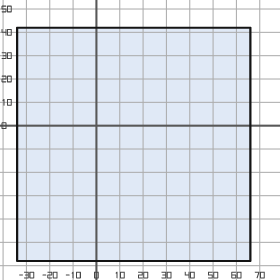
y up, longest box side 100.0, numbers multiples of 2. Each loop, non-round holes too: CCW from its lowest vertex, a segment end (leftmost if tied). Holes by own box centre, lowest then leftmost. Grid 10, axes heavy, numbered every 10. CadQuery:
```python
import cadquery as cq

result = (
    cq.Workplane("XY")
    .moveTo(-34.0, -58.0)
    .lineTo(66.0, -58.0)
    .lineTo(66.0, 42.0)
    .lineTo(-34.0, 42.0)
    .close()
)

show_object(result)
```